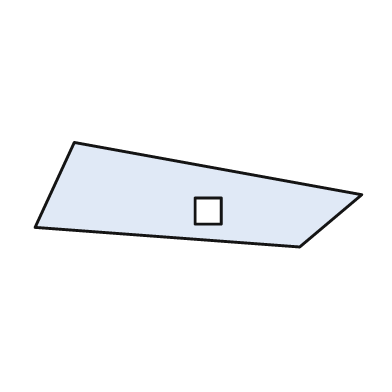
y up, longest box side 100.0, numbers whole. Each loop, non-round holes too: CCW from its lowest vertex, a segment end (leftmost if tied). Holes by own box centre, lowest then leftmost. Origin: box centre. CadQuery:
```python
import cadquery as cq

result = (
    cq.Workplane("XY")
    .moveTo(31.0, -16.0)
    .lineTo(50.0, 0.0)
    .lineTo(-38.0, 16.0)
    .lineTo(-50.0, -10.0)
    .close()
    .moveTo(-1.0, -9.0)
    .lineTo(7.0, -9.0)
    .lineTo(7.0, -1.0)
    .lineTo(-1.0, -1.0)
    .close()
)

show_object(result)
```